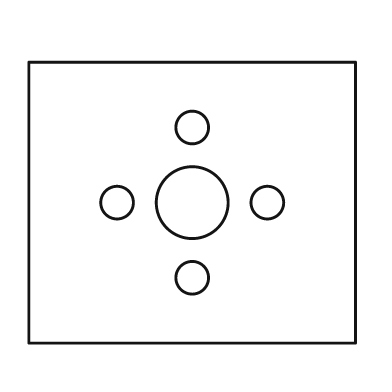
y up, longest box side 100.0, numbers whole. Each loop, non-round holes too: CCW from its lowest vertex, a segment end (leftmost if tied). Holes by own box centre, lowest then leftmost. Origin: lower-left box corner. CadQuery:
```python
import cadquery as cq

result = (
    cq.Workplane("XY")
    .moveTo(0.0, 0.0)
    .lineTo(100.0, 0.0)
    .lineTo(100.0, 86.0)
    .lineTo(0.0, 86.0)
    .close()
    .moveTo(50.0, 20.0)
    .circle(5.0)
    .moveTo(27.0, 43.0)
    .circle(5.0)
    .moveTo(50.0, 43.0)
    .circle(11.0)
    .moveTo(73.0, 43.0)
    .circle(5.0)
    .moveTo(50.0, 66.0)
    .circle(5.0)
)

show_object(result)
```